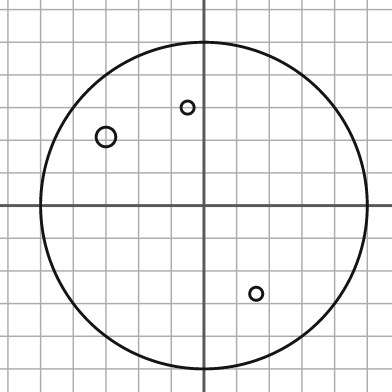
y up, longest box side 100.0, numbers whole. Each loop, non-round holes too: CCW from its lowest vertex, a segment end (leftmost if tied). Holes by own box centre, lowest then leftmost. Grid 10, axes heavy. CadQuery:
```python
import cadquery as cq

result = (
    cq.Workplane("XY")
    .moveTo(0.0, 0.0)
    .circle(50.0)
    .moveTo(16.0, -27.0)
    .circle(2.0)
    .moveTo(-30.0, 21.0)
    .circle(3.0)
    .moveTo(-5.0, 30.0)
    .circle(2.0)
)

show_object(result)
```